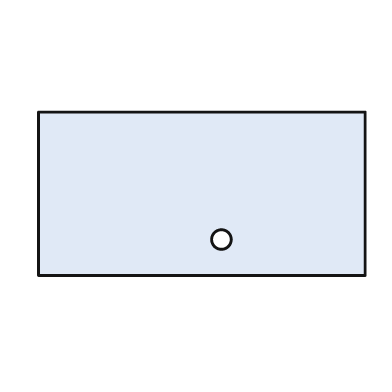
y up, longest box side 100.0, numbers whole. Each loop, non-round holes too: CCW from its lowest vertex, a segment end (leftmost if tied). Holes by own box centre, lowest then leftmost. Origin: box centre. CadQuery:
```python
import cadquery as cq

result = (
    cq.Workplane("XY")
    .moveTo(-50.0, -25.0)
    .lineTo(50.0, -25.0)
    .lineTo(50.0, 25.0)
    .lineTo(-50.0, 25.0)
    .close()
    .moveTo(6.0, -14.0)
    .circle(3.0)
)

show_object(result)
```